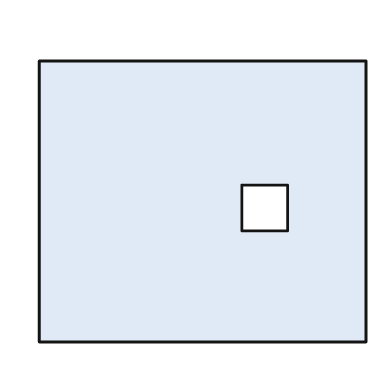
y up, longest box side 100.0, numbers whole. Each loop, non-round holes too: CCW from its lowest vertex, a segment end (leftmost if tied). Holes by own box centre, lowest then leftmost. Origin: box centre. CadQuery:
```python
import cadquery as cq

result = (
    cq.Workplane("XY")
    .moveTo(-50.0, -43.0)
    .lineTo(50.0, -43.0)
    .lineTo(50.0, 43.0)
    .lineTo(-50.0, 43.0)
    .close()
    .moveTo(12.0, -9.0)
    .lineTo(26.0, -9.0)
    .lineTo(26.0, 5.0)
    .lineTo(12.0, 5.0)
    .close()
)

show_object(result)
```